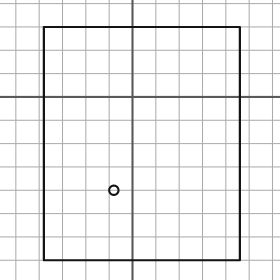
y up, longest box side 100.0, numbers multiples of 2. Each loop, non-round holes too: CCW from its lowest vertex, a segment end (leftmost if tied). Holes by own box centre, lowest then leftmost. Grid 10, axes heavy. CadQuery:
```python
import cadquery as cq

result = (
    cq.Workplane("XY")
    .moveTo(-38.0, -70.0)
    .lineTo(46.0, -70.0)
    .lineTo(46.0, 30.0)
    .lineTo(-38.0, 30.0)
    .close()
    .moveTo(-8.0, -40.0)
    .circle(2.0)
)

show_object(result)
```